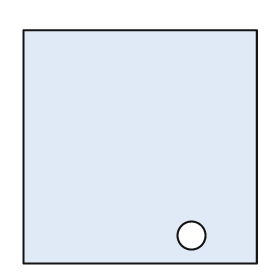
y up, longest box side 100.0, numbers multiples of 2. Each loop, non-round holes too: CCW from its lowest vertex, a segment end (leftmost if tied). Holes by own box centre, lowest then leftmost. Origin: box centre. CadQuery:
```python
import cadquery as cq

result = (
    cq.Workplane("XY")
    .moveTo(-50.0, -50.0)
    .lineTo(50.0, -50.0)
    .lineTo(50.0, 50.0)
    .lineTo(-50.0, 50.0)
    .close()
    .moveTo(22.0, -38.0)
    .circle(6.0)
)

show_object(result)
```